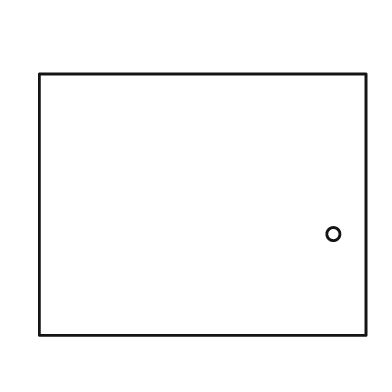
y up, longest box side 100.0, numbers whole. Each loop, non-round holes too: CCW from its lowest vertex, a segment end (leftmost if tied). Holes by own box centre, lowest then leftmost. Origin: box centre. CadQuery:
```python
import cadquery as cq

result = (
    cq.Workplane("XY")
    .moveTo(-50.0, -40.0)
    .lineTo(50.0, -40.0)
    .lineTo(50.0, 40.0)
    .lineTo(-50.0, 40.0)
    .close()
    .moveTo(40.0, -9.0)
    .circle(2.0)
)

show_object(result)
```